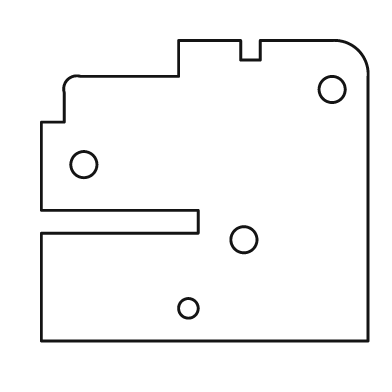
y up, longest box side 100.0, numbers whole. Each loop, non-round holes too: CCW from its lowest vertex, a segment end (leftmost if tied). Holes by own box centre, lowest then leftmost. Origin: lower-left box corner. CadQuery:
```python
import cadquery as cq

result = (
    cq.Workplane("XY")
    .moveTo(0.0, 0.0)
    .lineTo(100.0, 0.0)
    .lineTo(100.0, 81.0)
    .threePointArc((97.0, 89.0), (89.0, 92.0))
    .lineTo(67.0, 92.0)
    .lineTo(67.0, 86.0)
    .lineTo(61.0, 86.0)
    .lineTo(61.0, 92.0)
    .lineTo(42.0, 92.0)
    .lineTo(42.0, 81.0)
    .lineTo(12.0, 81.0)
    .threePointArc((8.0, 80.0), (7.0, 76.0))
    .lineTo(7.0, 67.0)
    .lineTo(0.0, 67.0)
    .lineTo(0.0, 40.0)
    .lineTo(48.0, 40.0)
    .lineTo(48.0, 33.0)
    .lineTo(0.0, 33.0)
    .close()
    .moveTo(45.0, 10.0)
    .circle(3.0)
    .moveTo(62.0, 31.0)
    .circle(4.0)
    .moveTo(13.0, 54.0)
    .circle(4.0)
    .moveTo(89.0, 77.0)
    .circle(4.0)
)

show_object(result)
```